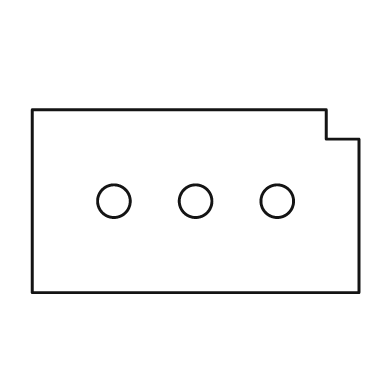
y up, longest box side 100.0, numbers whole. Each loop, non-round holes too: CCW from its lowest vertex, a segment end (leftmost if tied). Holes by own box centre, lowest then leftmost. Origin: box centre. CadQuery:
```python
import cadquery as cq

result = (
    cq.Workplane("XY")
    .moveTo(-50.0, -28.0)
    .lineTo(50.0, -28.0)
    .lineTo(50.0, 19.0)
    .lineTo(40.0, 19.0)
    .lineTo(40.0, 28.0)
    .lineTo(-50.0, 28.0)
    .close()
    .moveTo(-25.0, 0.0)
    .circle(5.0)
    .moveTo(0.0, 0.0)
    .circle(5.0)
    .moveTo(25.0, 0.0)
    .circle(5.0)
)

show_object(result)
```